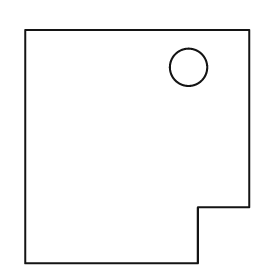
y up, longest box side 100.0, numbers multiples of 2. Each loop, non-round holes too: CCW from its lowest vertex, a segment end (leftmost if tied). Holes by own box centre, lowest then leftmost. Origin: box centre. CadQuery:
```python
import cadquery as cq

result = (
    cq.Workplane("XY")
    .moveTo(-48.0, -50.0)
    .lineTo(26.0, -50.0)
    .lineTo(26.0, -26.0)
    .lineTo(48.0, -26.0)
    .lineTo(48.0, 50.0)
    .lineTo(-48.0, 50.0)
    .close()
    .moveTo(22.0, 34.0)
    .circle(8.0)
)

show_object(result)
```